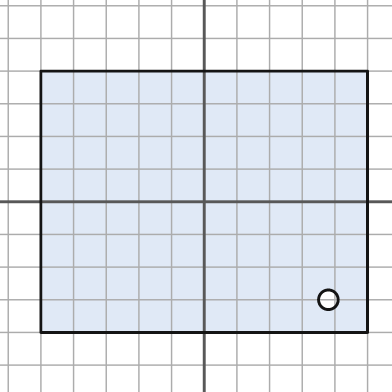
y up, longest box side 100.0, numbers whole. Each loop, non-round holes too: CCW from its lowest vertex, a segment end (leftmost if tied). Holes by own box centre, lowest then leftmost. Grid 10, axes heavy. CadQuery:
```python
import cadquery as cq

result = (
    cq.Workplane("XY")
    .moveTo(-50.0, -40.0)
    .lineTo(50.0, -40.0)
    .lineTo(50.0, 40.0)
    .lineTo(-50.0, 40.0)
    .close()
    .moveTo(38.0, -30.0)
    .circle(3.0)
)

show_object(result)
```